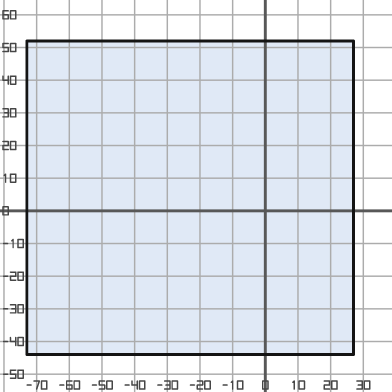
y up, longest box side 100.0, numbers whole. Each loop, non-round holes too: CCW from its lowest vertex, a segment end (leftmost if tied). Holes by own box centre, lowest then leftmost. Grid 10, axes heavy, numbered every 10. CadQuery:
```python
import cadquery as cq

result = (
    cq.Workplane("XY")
    .moveTo(-73.0, -44.0)
    .lineTo(27.0, -44.0)
    .lineTo(27.0, 52.0)
    .lineTo(-73.0, 52.0)
    .close()
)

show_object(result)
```